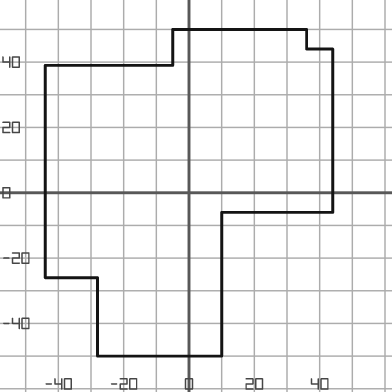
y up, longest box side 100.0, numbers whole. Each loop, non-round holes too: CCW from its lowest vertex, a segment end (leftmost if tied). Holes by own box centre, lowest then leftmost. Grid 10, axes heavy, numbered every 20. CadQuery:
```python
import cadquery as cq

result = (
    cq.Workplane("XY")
    .moveTo(-28.0, -50.0)
    .lineTo(10.0, -50.0)
    .lineTo(10.0, -6.0)
    .lineTo(44.0, -6.0)
    .lineTo(44.0, 44.0)
    .lineTo(36.0, 44.0)
    .lineTo(36.0, 50.0)
    .lineTo(-5.0, 50.0)
    .lineTo(-5.0, 39.0)
    .lineTo(-44.0, 39.0)
    .lineTo(-44.0, -26.0)
    .lineTo(-28.0, -26.0)
    .close()
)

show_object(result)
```